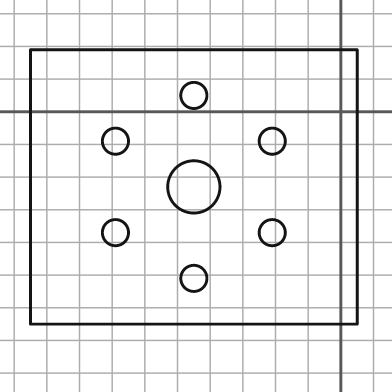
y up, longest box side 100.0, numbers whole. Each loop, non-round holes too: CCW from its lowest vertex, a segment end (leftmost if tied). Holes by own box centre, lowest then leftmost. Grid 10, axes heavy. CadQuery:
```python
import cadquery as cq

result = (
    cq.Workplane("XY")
    .moveTo(-95.0, -65.0)
    .lineTo(5.0, -65.0)
    .lineTo(5.0, 19.0)
    .lineTo(-95.0, 19.0)
    .close()
    .moveTo(-45.0, -51.0)
    .circle(4.0)
    .moveTo(-69.0, -37.0)
    .circle(4.0)
    .moveTo(-21.0, -37.0)
    .circle(4.0)
    .moveTo(-45.0, -23.0)
    .circle(8.0)
    .moveTo(-69.0, -9.0)
    .circle(4.0)
    .moveTo(-21.0, -9.0)
    .circle(4.0)
    .moveTo(-45.0, 5.0)
    .circle(4.0)
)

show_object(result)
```